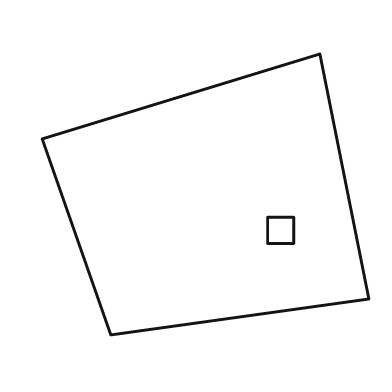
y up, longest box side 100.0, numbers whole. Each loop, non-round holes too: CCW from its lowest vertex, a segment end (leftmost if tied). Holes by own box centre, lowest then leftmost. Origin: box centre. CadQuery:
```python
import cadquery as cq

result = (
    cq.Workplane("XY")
    .moveTo(-29.0, -43.0)
    .lineTo(50.0, -32.0)
    .lineTo(35.0, 43.0)
    .lineTo(-50.0, 17.0)
    .close()
    .moveTo(19.0, -15.0)
    .lineTo(27.0, -15.0)
    .lineTo(27.0, -7.0)
    .lineTo(19.0, -7.0)
    .close()
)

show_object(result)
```